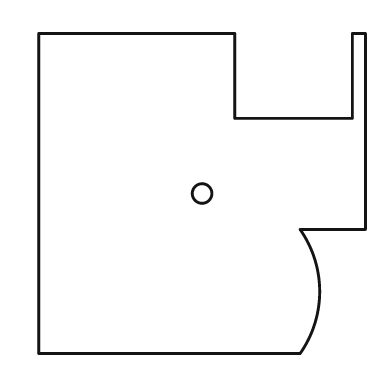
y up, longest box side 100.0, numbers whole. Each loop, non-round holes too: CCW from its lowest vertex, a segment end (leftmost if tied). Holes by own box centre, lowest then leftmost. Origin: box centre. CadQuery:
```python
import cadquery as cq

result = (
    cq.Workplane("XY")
    .moveTo(-50.0, -49.0)
    .lineTo(30.0, -49.0)
    .threePointArc((36.0, -30.0), (30.0, -11.0))
    .lineTo(50.0, -11.0)
    .lineTo(50.0, 49.0)
    .lineTo(46.0, 49.0)
    .lineTo(46.0, 23.0)
    .lineTo(10.0, 23.0)
    .lineTo(10.0, 49.0)
    .lineTo(-50.0, 49.0)
    .close()
    .moveTo(0.0, 0.0)
    .circle(3.0)
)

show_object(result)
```